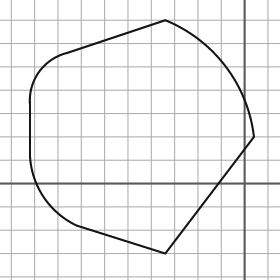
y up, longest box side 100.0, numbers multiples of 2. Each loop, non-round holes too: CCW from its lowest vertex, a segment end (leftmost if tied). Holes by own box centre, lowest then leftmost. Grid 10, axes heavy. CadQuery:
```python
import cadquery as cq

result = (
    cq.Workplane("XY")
    .moveTo(-34.0, -30.0)
    .lineTo(4.0, 20.0)
    .threePointArc((-8.0, 50.0), (-34.0, 70.0))
    .lineTo(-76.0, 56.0)
    .threePointArc((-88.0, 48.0), (-92.0, 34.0))
    .lineTo(-92.0, 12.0)
    .threePointArc((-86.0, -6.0), (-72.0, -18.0))
    .close()
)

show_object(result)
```